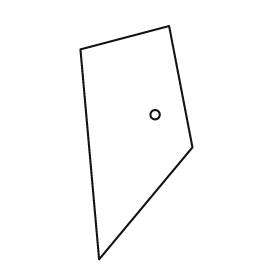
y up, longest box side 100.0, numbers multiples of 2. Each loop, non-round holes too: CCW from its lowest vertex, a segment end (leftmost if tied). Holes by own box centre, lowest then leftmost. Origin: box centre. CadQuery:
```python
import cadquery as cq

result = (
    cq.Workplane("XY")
    .moveTo(-16.0, -50.0)
    .lineTo(24.0, -2.0)
    .lineTo(14.0, 50.0)
    .lineTo(-24.0, 40.0)
    .close()
    .moveTo(8.0, 12.0)
    .circle(2.0)
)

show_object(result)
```